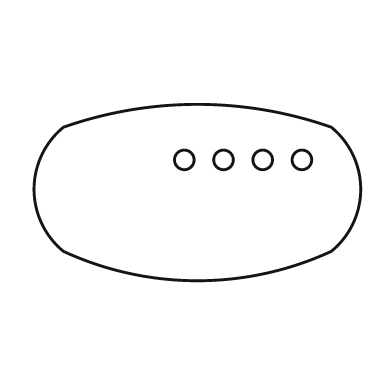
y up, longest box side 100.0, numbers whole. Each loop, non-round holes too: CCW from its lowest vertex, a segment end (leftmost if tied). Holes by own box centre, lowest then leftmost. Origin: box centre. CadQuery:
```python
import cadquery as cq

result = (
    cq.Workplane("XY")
    .moveTo(-41.0, -18.0)
    .threePointArc((0.0, -27.0), (41.0, -18.0))
    .threePointArc((50.0, 1.0), (41.0, 20.0))
    .threePointArc((0.0, 27.0), (-41.0, 20.0))
    .threePointArc((-50.0, 1.0), (-41.0, -18.0))
    .close()
    .moveTo(-4.0, 10.0)
    .circle(3.0)
    .moveTo(8.0, 10.0)
    .circle(3.0)
    .moveTo(20.0, 10.0)
    .circle(3.0)
    .moveTo(32.0, 10.0)
    .circle(3.0)
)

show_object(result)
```